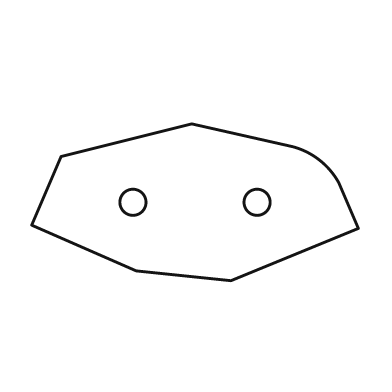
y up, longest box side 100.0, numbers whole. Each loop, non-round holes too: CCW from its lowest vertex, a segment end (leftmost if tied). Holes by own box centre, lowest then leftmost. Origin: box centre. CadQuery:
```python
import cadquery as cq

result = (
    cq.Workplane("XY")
    .moveTo(11.0, -24.0)
    .lineTo(50.0, -8.0)
    .lineTo(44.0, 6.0)
    .threePointArc((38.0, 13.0), (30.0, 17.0))
    .lineTo(-1.0, 24.0)
    .lineTo(-41.0, 14.0)
    .lineTo(-50.0, -7.0)
    .lineTo(-18.0, -21.0)
    .close()
    .moveTo(-19.0, 0.0)
    .circle(4.0)
    .moveTo(19.0, 0.0)
    .circle(4.0)
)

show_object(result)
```